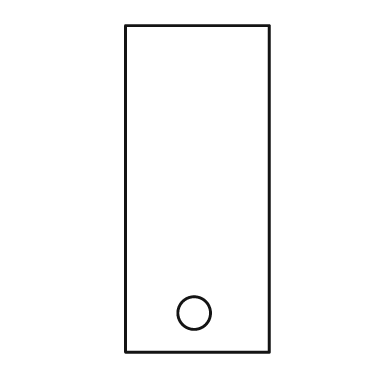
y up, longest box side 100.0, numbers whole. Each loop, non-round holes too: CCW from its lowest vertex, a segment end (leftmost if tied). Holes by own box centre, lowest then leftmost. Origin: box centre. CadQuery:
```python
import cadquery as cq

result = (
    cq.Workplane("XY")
    .moveTo(-22.0, -50.0)
    .lineTo(22.0, -50.0)
    .lineTo(22.0, 50.0)
    .lineTo(-22.0, 50.0)
    .close()
    .moveTo(-1.0, -38.0)
    .circle(5.0)
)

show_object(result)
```